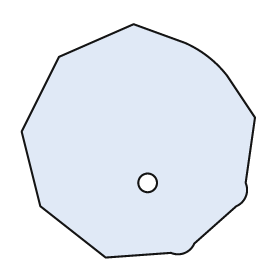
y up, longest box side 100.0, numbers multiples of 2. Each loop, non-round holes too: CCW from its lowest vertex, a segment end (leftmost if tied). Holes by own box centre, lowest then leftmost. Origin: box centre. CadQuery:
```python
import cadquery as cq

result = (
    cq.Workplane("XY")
    .moveTo(-14.0, -50.0)
    .lineTo(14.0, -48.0)
    .threePointArc((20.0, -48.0), (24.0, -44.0))
    .lineTo(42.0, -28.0)
    .threePointArc((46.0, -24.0), (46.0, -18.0))
    .lineTo(50.0, 10.0)
    .lineTo(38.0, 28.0)
    .threePointArc((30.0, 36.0), (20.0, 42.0))
    .lineTo(-2.0, 50.0)
    .lineTo(-34.0, 36.0)
    .lineTo(-50.0, 4.0)
    .lineTo(-42.0, -28.0)
    .close()
    .moveTo(4.0, -18.0)
    .circle(4.0)
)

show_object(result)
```